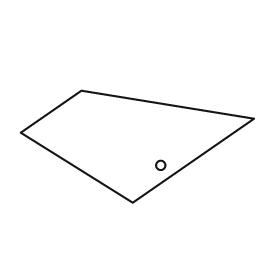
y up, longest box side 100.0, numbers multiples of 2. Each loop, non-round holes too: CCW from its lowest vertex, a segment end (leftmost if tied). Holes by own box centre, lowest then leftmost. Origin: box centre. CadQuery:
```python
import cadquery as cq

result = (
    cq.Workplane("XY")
    .moveTo(-2.0, -24.0)
    .lineTo(50.0, 12.0)
    .lineTo(-24.0, 24.0)
    .lineTo(-50.0, 6.0)
    .close()
    .moveTo(10.0, -8.0)
    .circle(2.0)
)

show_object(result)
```